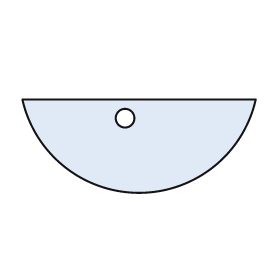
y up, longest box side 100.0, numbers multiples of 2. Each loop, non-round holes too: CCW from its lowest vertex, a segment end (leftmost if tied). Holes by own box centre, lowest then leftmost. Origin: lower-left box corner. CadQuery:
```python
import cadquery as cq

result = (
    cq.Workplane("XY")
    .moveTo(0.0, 40.0)
    .threePointArc((50.0, 0.0), (100.0, 40.0))
    .close()
    .moveTo(44.0, 32.0)
    .circle(4.0)
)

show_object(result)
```